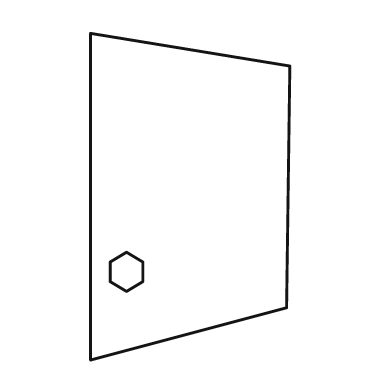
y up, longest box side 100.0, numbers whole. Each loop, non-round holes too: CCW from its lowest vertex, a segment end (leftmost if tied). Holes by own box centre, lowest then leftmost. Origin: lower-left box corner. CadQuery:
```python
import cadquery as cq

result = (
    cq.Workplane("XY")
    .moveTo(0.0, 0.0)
    .lineTo(60.0, 16.0)
    .lineTo(61.0, 90.0)
    .lineTo(0.0, 100.0)
    .close()
    .moveTo(11.0, 21.0)
    .lineTo(16.0, 24.0)
    .lineTo(16.0, 30.0)
    .lineTo(11.0, 33.0)
    .lineTo(6.0, 30.0)
    .lineTo(6.0, 24.0)
    .close()
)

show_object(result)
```